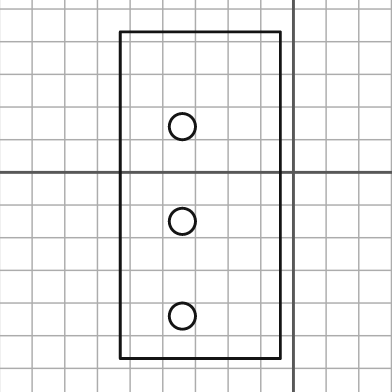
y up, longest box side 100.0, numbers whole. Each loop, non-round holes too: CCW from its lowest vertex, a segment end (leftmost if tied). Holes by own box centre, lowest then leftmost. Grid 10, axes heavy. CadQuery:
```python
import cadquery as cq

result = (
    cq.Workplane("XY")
    .moveTo(-53.0, -57.0)
    .lineTo(-4.0, -57.0)
    .lineTo(-4.0, 43.0)
    .lineTo(-53.0, 43.0)
    .close()
    .moveTo(-34.0, -44.0)
    .circle(4.0)
    .moveTo(-34.0, -15.0)
    .circle(4.0)
    .moveTo(-34.0, 14.0)
    .circle(4.0)
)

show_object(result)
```